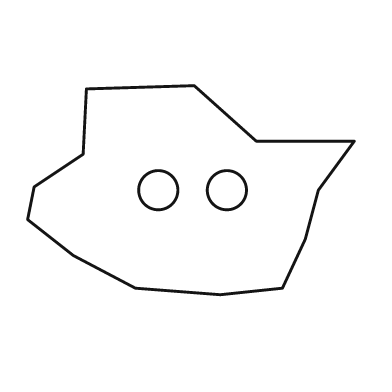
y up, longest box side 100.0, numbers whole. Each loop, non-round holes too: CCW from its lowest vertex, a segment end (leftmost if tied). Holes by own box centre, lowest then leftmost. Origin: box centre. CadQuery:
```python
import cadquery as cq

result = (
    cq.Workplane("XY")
    .moveTo(9.0, -32.0)
    .lineTo(28.0, -30.0)
    .lineTo(35.0, -15.0)
    .lineTo(39.0, 0.0)
    .lineTo(50.0, 15.0)
    .lineTo(20.0, 15.0)
    .lineTo(1.0, 32.0)
    .lineTo(-32.0, 31.0)
    .lineTo(-33.0, 11.0)
    .lineTo(-48.0, 1.0)
    .lineTo(-50.0, -9.0)
    .lineTo(-36.0, -20.0)
    .lineTo(-17.0, -30.0)
    .close()
    .moveTo(-10.0, 0.0)
    .circle(6.0)
    .moveTo(11.0, 0.0)
    .circle(6.0)
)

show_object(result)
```